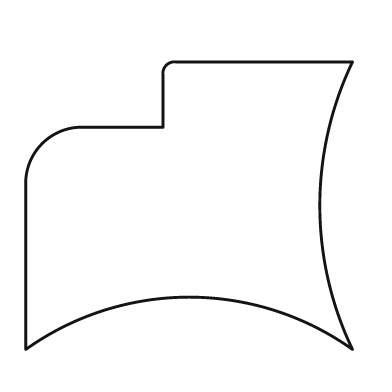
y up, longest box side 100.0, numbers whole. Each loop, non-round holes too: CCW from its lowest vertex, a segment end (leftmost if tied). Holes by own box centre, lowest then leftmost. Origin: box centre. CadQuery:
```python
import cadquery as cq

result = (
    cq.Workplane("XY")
    .moveTo(-50.0, -44.0)
    .threePointArc((0.0, -28.0), (50.0, -44.0))
    .threePointArc((40.0, 0.0), (50.0, 44.0))
    .lineTo(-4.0, 44.0)
    .threePointArc((-7.0, 43.0), (-8.0, 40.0))
    .lineTo(-8.0, 24.0)
    .lineTo(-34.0, 24.0)
    .threePointArc((-45.0, 19.0), (-50.0, 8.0))
    .close()
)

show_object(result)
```